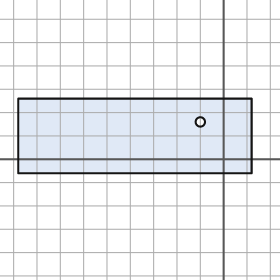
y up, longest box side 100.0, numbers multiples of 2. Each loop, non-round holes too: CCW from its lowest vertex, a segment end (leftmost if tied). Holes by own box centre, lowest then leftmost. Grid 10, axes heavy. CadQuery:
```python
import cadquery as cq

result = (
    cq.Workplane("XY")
    .moveTo(-88.0, -6.0)
    .lineTo(12.0, -6.0)
    .lineTo(12.0, 26.0)
    .lineTo(-88.0, 26.0)
    .close()
    .moveTo(-10.0, 16.0)
    .circle(2.0)
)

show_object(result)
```